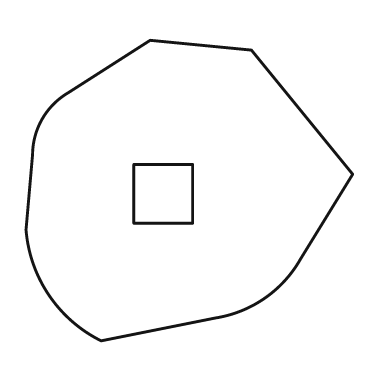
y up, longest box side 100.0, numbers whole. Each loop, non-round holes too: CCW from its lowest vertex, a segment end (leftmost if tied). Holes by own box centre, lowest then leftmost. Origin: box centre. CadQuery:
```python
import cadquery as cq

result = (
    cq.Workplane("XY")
    .moveTo(-27.0, -46.0)
    .lineTo(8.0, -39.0)
    .threePointArc((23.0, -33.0), (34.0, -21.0))
    .lineTo(50.0, 5.0)
    .lineTo(19.0, 43.0)
    .lineTo(-12.0, 46.0)
    .lineTo(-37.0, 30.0)
    .threePointArc((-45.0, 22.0), (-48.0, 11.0))
    .lineTo(-50.0, -12.0)
    .threePointArc((-43.0, -32.0), (-27.0, -46.0))
    .close()
    .moveTo(-17.0, -10.0)
    .lineTo(1.0, -10.0)
    .lineTo(1.0, 8.0)
    .lineTo(-17.0, 8.0)
    .close()
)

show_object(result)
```